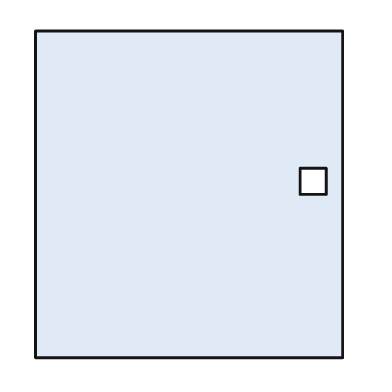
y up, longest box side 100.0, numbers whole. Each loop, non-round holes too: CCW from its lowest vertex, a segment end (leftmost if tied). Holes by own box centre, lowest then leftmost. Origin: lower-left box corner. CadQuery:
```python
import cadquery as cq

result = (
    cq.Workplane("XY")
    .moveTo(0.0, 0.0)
    .lineTo(94.0, 0.0)
    .lineTo(94.0, 100.0)
    .lineTo(0.0, 100.0)
    .close()
    .moveTo(81.0, 50.0)
    .lineTo(89.0, 50.0)
    .lineTo(89.0, 58.0)
    .lineTo(81.0, 58.0)
    .close()
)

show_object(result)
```